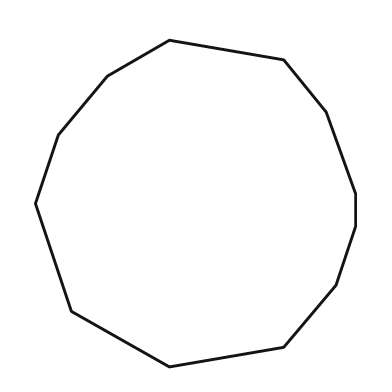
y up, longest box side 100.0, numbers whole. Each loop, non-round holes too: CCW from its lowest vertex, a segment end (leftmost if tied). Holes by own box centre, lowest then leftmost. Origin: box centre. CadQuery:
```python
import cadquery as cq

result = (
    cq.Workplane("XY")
    .moveTo(-8.0, -50.0)
    .lineTo(27.0, -44.0)
    .lineTo(43.0, -25.0)
    .lineTo(49.0, -7.0)
    .lineTo(49.0, 3.0)
    .lineTo(40.0, 28.0)
    .lineTo(27.0, 44.0)
    .lineTo(-8.0, 50.0)
    .lineTo(-27.0, 39.0)
    .lineTo(-42.0, 21.0)
    .lineTo(-49.0, 0.0)
    .lineTo(-38.0, -33.0)
    .close()
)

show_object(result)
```